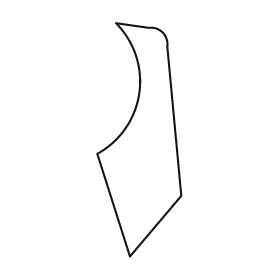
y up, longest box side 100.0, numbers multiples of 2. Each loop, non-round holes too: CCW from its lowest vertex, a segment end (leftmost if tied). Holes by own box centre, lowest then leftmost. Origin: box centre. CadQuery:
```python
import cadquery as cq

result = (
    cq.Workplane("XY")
    .moveTo(-4.0, -50.0)
    .lineTo(18.0, -24.0)
    .lineTo(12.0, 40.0)
    .threePointArc((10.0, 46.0), (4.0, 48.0))
    .lineTo(-10.0, 50.0)
    .threePointArc((0.0, 20.0), (-18.0, -6.0))
    .close()
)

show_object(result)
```